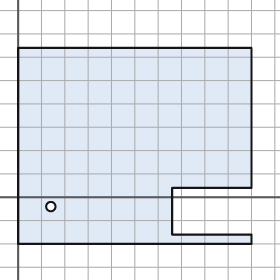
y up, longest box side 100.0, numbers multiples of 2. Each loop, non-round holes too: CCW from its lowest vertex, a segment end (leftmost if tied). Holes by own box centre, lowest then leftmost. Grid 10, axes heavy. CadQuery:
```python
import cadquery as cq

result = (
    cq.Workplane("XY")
    .moveTo(0.0, -20.0)
    .lineTo(100.0, -20.0)
    .lineTo(100.0, -16.0)
    .lineTo(66.0, -16.0)
    .lineTo(66.0, 4.0)
    .lineTo(100.0, 4.0)
    .lineTo(100.0, 64.0)
    .lineTo(0.0, 64.0)
    .close()
    .moveTo(14.0, -4.0)
    .circle(2.0)
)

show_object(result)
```